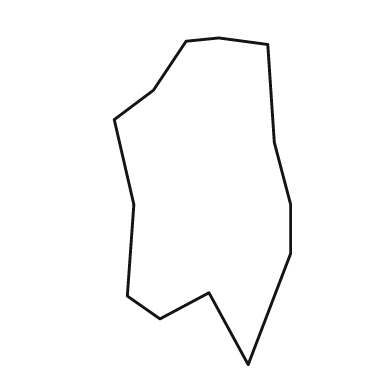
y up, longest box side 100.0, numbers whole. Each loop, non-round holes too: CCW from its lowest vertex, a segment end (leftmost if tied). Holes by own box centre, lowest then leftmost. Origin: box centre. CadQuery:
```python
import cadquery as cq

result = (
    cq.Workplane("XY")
    .moveTo(14.0, -50.0)
    .lineTo(27.0, -16.0)
    .lineTo(27.0, -1.0)
    .lineTo(22.0, 18.0)
    .lineTo(20.0, 48.0)
    .lineTo(5.0, 50.0)
    .lineTo(-5.0, 49.0)
    .lineTo(-15.0, 34.0)
    .lineTo(-27.0, 25.0)
    .lineTo(-21.0, -1.0)
    .lineTo(-23.0, -29.0)
    .lineTo(-13.0, -36.0)
    .lineTo(2.0, -28.0)
    .close()
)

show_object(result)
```